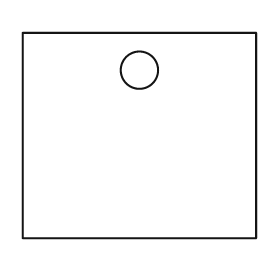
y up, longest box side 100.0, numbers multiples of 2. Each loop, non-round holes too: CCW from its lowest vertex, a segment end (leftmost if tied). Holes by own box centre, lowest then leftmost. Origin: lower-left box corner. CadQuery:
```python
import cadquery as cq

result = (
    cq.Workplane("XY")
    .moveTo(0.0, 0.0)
    .lineTo(100.0, 0.0)
    .lineTo(100.0, 88.0)
    .lineTo(0.0, 88.0)
    .close()
    .moveTo(50.0, 72.0)
    .circle(8.0)
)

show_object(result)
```